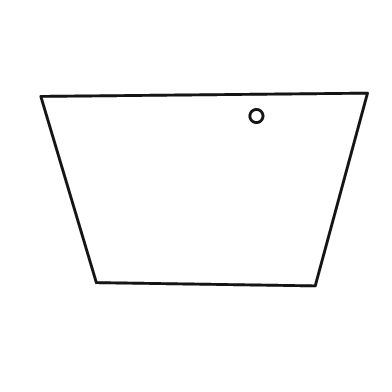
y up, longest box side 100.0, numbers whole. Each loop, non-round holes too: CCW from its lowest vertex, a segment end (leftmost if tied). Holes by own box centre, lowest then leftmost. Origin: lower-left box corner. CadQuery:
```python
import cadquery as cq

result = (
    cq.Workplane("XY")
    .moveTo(84.0, 0.0)
    .lineTo(100.0, 59.0)
    .lineTo(0.0, 58.0)
    .lineTo(17.0, 1.0)
    .close()
    .moveTo(66.0, 52.0)
    .circle(2.0)
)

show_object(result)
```